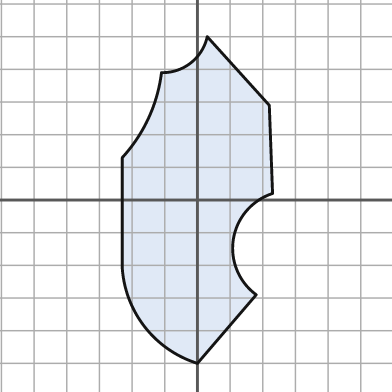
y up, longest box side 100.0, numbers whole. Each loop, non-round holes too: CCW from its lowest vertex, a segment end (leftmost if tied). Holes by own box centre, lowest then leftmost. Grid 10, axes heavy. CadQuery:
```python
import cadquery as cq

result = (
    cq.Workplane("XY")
    .moveTo(0.0, -50.0)
    .lineTo(18.0, -29.0)
    .threePointArc((11.0, -12.0), (23.0, 2.0))
    .lineTo(22.0, 29.0)
    .lineTo(3.0, 50.0)
    .threePointArc((-2.0, 42.0), (-11.0, 39.0))
    .threePointArc((-15.0, 25.0), (-23.0, 13.0))
    .lineTo(-23.0, -21.0)
    .threePointArc((-16.0, -39.0), (0.0, -50.0))
    .close()
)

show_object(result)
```